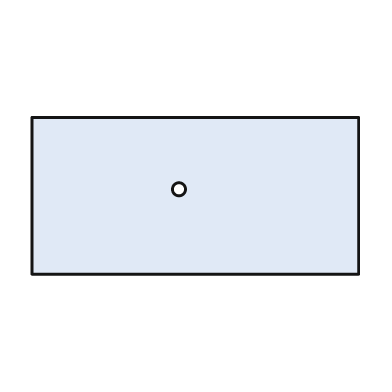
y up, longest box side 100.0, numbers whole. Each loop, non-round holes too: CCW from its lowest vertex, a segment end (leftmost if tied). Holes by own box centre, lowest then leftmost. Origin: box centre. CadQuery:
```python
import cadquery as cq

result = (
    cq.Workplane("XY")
    .moveTo(-50.0, -24.0)
    .lineTo(50.0, -24.0)
    .lineTo(50.0, 24.0)
    .lineTo(-50.0, 24.0)
    .close()
    .moveTo(-5.0, 2.0)
    .circle(2.0)
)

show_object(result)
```